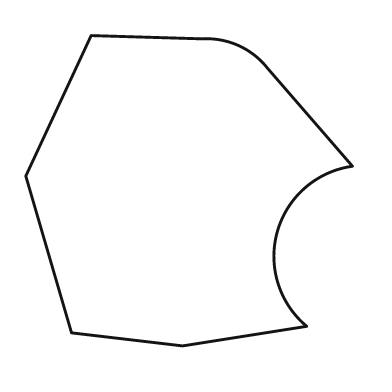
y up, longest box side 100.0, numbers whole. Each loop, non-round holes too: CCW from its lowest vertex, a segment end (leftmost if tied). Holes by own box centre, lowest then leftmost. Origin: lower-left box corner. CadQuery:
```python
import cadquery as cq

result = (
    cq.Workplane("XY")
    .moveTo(48.0, 0.0)
    .lineTo(86.0, 6.0)
    .threePointArc((77.0, 35.0), (100.0, 55.0))
    .lineTo(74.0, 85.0)
    .threePointArc((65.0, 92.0), (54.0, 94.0))
    .lineTo(20.0, 95.0)
    .lineTo(0.0, 52.0)
    .lineTo(14.0, 4.0)
    .close()
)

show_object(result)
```